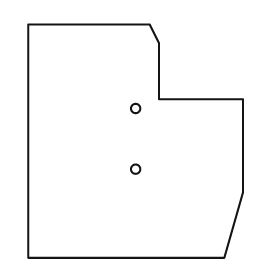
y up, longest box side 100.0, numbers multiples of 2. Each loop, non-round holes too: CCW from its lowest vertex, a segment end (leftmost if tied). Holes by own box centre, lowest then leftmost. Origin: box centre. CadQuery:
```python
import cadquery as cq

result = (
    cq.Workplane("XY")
    .moveTo(-46.0, -50.0)
    .lineTo(38.0, -50.0)
    .lineTo(46.0, -22.0)
    .lineTo(46.0, 18.0)
    .lineTo(10.0, 18.0)
    .lineTo(10.0, 42.0)
    .lineTo(6.0, 50.0)
    .lineTo(-46.0, 50.0)
    .close()
    .moveTo(0.0, -12.0)
    .circle(2.0)
    .moveTo(0.0, 14.0)
    .circle(2.0)
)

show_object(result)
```